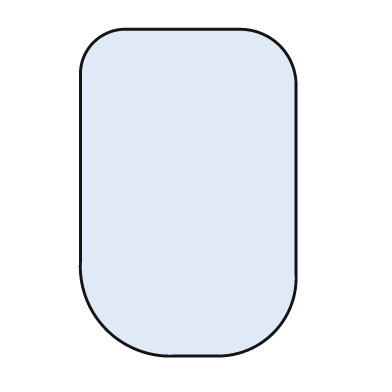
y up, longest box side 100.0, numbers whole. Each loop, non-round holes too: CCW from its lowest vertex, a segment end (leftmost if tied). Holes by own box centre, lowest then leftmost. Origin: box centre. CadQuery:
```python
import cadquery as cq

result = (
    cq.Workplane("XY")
    .moveTo(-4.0, -50.0)
    .lineTo(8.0, -50.0)
    .threePointArc((26.0, -43.0), (33.0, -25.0))
    .lineTo(33.0, 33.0)
    .threePointArc((28.0, 45.0), (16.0, 50.0))
    .lineTo(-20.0, 50.0)
    .threePointArc((-29.0, 46.0), (-33.0, 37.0))
    .lineTo(-33.0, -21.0)
    .threePointArc((-25.0, -42.0), (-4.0, -50.0))
    .close()
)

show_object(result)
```